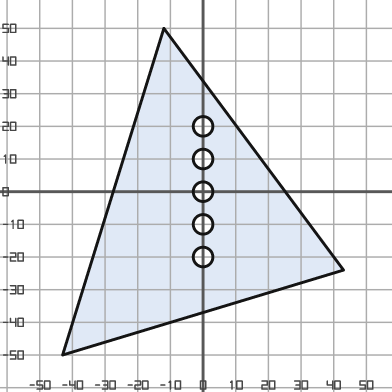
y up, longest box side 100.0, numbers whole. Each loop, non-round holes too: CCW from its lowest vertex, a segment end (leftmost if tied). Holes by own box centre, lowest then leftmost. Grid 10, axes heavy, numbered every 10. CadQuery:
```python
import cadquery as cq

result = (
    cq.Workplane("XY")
    .moveTo(-43.0, -50.0)
    .lineTo(43.0, -24.0)
    .lineTo(-12.0, 50.0)
    .close()
    .moveTo(0.0, -20.0)
    .circle(3.0)
    .moveTo(0.0, -10.0)
    .circle(3.0)
    .moveTo(0.0, 0.0)
    .circle(3.0)
    .moveTo(0.0, 10.0)
    .circle(3.0)
    .moveTo(0.0, 20.0)
    .circle(3.0)
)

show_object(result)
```